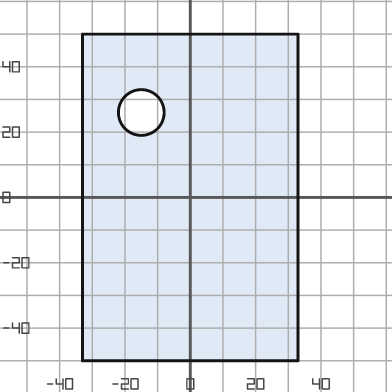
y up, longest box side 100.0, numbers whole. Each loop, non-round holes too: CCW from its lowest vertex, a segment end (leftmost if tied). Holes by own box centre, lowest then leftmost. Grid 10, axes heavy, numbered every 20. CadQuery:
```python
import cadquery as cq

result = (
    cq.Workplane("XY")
    .moveTo(-33.0, -50.0)
    .lineTo(33.0, -50.0)
    .lineTo(33.0, 50.0)
    .lineTo(-33.0, 50.0)
    .close()
    .moveTo(-15.0, 26.0)
    .circle(7.0)
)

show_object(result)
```